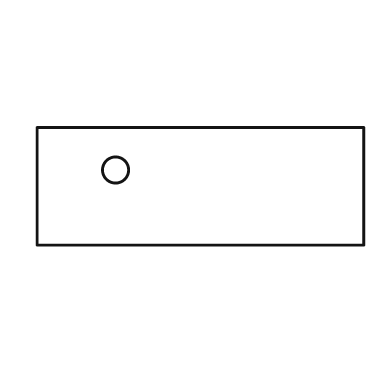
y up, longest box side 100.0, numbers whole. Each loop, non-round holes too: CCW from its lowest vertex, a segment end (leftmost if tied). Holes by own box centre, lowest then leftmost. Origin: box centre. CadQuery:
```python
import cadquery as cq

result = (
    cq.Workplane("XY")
    .moveTo(-50.0, -18.0)
    .lineTo(50.0, -18.0)
    .lineTo(50.0, 18.0)
    .lineTo(-50.0, 18.0)
    .close()
    .moveTo(-26.0, 5.0)
    .circle(4.0)
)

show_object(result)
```